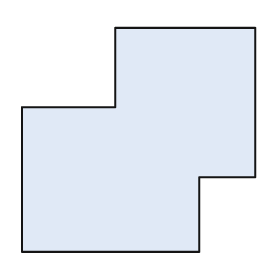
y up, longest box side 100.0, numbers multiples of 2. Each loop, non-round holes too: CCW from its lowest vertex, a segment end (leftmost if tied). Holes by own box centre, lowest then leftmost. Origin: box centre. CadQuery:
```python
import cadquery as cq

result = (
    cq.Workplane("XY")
    .moveTo(-50.0, -48.0)
    .lineTo(26.0, -48.0)
    .lineTo(26.0, -16.0)
    .lineTo(50.0, -16.0)
    .lineTo(50.0, 48.0)
    .lineTo(-10.0, 48.0)
    .lineTo(-10.0, 14.0)
    .lineTo(-50.0, 14.0)
    .close()
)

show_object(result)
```